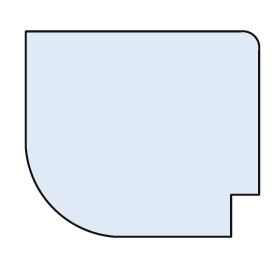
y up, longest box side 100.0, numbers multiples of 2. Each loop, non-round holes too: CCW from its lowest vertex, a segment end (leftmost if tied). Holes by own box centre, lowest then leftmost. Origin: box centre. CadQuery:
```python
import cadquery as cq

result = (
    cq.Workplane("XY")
    .moveTo(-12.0, -44.0)
    .lineTo(38.0, -44.0)
    .lineTo(38.0, -26.0)
    .lineTo(50.0, -26.0)
    .lineTo(50.0, 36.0)
    .threePointArc((48.0, 42.0), (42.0, 44.0))
    .lineTo(-50.0, 44.0)
    .lineTo(-50.0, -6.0)
    .threePointArc((-38.0, -32.0), (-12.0, -44.0))
    .close()
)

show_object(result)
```